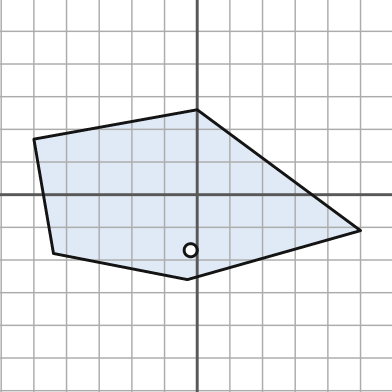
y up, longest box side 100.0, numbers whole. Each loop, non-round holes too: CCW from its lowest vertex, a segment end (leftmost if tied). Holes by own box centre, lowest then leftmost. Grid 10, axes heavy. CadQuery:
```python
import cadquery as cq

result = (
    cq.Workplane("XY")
    .moveTo(-3.0, -26.0)
    .lineTo(50.0, -11.0)
    .lineTo(0.0, 26.0)
    .lineTo(-50.0, 17.0)
    .lineTo(-44.0, -18.0)
    .close()
    .moveTo(-2.0, -17.0)
    .circle(2.0)
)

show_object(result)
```